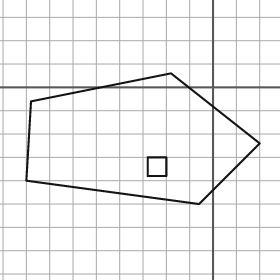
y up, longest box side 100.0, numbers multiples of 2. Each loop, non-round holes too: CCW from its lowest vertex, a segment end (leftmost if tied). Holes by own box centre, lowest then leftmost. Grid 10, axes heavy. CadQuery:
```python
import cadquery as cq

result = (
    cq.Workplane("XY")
    .moveTo(-6.0, -50.0)
    .lineTo(20.0, -24.0)
    .lineTo(-18.0, 6.0)
    .lineTo(-78.0, -6.0)
    .lineTo(-80.0, -40.0)
    .close()
    .moveTo(-28.0, -38.0)
    .lineTo(-20.0, -38.0)
    .lineTo(-20.0, -30.0)
    .lineTo(-28.0, -30.0)
    .close()
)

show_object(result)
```